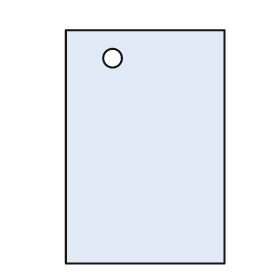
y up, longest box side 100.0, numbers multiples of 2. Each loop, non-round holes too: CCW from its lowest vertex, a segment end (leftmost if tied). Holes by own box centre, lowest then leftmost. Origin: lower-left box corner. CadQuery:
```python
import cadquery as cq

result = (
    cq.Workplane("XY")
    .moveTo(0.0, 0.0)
    .lineTo(68.0, 0.0)
    .lineTo(68.0, 100.0)
    .lineTo(0.0, 100.0)
    .close()
    .moveTo(20.0, 88.0)
    .circle(4.0)
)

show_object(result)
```